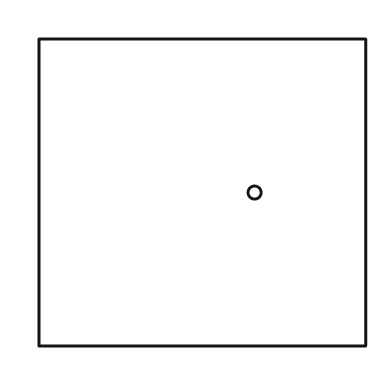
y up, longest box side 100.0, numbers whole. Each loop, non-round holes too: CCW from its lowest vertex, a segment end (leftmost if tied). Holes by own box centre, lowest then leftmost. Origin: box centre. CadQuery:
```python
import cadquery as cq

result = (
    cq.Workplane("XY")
    .moveTo(-50.0, -47.0)
    .lineTo(50.0, -47.0)
    .lineTo(50.0, 47.0)
    .lineTo(-50.0, 47.0)
    .close()
    .moveTo(16.0, 0.0)
    .circle(2.0)
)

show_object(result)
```